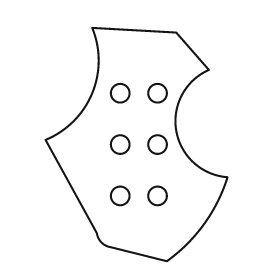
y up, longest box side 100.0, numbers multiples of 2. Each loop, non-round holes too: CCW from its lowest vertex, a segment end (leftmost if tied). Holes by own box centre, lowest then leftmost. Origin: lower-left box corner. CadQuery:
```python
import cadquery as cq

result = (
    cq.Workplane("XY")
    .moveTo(52.0, 0.0)
    .threePointArc((68.0, 16.0), (78.0, 36.0))
    .threePointArc((56.0, 56.0), (70.0, 82.0))
    .lineTo(56.0, 98.0)
    .lineTo(20.0, 100.0)
    .threePointArc((20.0, 72.0), (0.0, 52.0))
    .lineTo(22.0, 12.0)
    .threePointArc((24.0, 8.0), (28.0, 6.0))
    .close()
    .moveTo(32.0, 28.0)
    .circle(4.0)
    .moveTo(48.0, 28.0)
    .circle(4.0)
    .moveTo(32.0, 50.0)
    .circle(4.0)
    .moveTo(48.0, 50.0)
    .circle(4.0)
    .moveTo(32.0, 72.0)
    .circle(4.0)
    .moveTo(48.0, 72.0)
    .circle(4.0)
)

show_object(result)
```